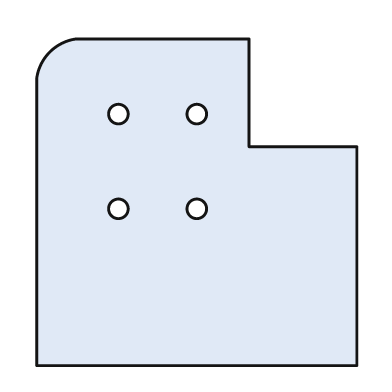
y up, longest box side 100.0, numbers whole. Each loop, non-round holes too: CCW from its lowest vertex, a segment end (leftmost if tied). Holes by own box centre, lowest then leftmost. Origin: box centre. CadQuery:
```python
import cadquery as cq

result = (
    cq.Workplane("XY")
    .moveTo(-49.0, -50.0)
    .lineTo(49.0, -50.0)
    .lineTo(49.0, 17.0)
    .lineTo(16.0, 17.0)
    .lineTo(16.0, 50.0)
    .lineTo(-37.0, 50.0)
    .threePointArc((-45.0, 46.0), (-49.0, 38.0))
    .close()
    .moveTo(-24.0, -2.0)
    .circle(3.0)
    .moveTo(0.0, -2.0)
    .circle(3.0)
    .moveTo(-24.0, 27.0)
    .circle(3.0)
    .moveTo(0.0, 27.0)
    .circle(3.0)
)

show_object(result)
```